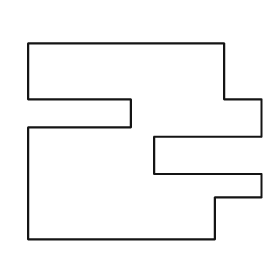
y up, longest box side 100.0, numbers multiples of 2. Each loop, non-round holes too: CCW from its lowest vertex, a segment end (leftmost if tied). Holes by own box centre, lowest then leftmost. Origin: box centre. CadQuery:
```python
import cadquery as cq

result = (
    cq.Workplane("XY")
    .moveTo(-50.0, -42.0)
    .lineTo(30.0, -42.0)
    .lineTo(30.0, -24.0)
    .lineTo(50.0, -24.0)
    .lineTo(50.0, -14.0)
    .lineTo(4.0, -14.0)
    .lineTo(4.0, 2.0)
    .lineTo(50.0, 2.0)
    .lineTo(50.0, 18.0)
    .lineTo(34.0, 18.0)
    .lineTo(34.0, 42.0)
    .lineTo(-50.0, 42.0)
    .lineTo(-50.0, 18.0)
    .lineTo(-6.0, 18.0)
    .lineTo(-6.0, 6.0)
    .lineTo(-50.0, 6.0)
    .close()
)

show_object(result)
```